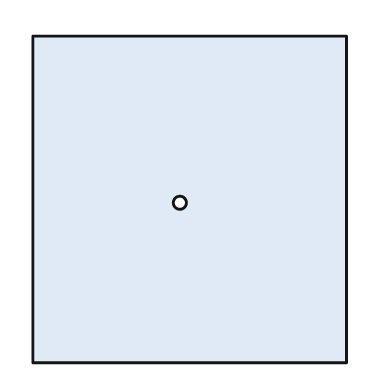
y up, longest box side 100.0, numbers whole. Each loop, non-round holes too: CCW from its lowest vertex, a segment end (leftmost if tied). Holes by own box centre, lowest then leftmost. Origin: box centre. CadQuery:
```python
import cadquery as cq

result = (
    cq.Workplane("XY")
    .moveTo(-48.0, -50.0)
    .lineTo(48.0, -50.0)
    .lineTo(48.0, 50.0)
    .lineTo(-48.0, 50.0)
    .close()
    .moveTo(-3.0, -1.0)
    .circle(2.0)
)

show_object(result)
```